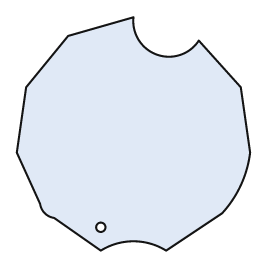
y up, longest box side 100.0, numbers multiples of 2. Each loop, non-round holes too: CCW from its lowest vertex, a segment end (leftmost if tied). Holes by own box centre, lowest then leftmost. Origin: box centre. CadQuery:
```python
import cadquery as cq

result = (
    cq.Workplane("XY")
    .moveTo(-14.0, -50.0)
    .threePointArc((0.0, -46.0), (14.0, -50.0))
    .lineTo(38.0, -34.0)
    .threePointArc((46.0, -22.0), (50.0, -8.0))
    .lineTo(46.0, 20.0)
    .lineTo(28.0, 40.0)
    .threePointArc((10.0, 34.0), (0.0, 50.0))
    .lineTo(-28.0, 42.0)
    .lineTo(-46.0, 20.0)
    .lineTo(-50.0, -8.0)
    .lineTo(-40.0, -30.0)
    .threePointArc((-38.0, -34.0), (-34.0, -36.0))
    .close()
    .moveTo(-14.0, -40.0)
    .circle(2.0)
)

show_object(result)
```